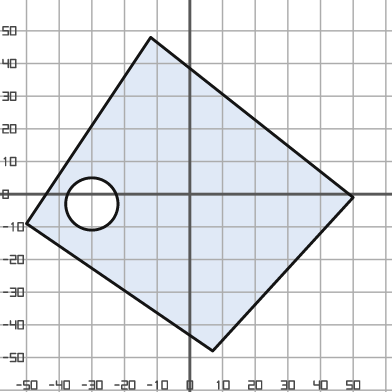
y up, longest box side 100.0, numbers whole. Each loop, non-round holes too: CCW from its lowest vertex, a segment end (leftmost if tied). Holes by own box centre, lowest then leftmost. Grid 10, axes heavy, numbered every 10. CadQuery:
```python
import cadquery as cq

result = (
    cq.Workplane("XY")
    .moveTo(7.0, -48.0)
    .lineTo(50.0, -1.0)
    .lineTo(-12.0, 48.0)
    .lineTo(-50.0, -9.0)
    .close()
    .moveTo(-30.0, -3.0)
    .circle(8.0)
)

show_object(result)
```